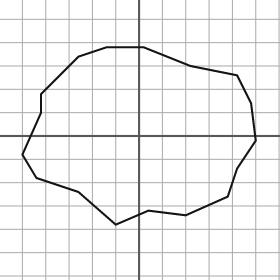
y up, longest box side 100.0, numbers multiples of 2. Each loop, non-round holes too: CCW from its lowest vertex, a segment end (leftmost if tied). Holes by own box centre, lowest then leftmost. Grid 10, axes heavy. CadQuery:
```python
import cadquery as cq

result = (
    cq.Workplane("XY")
    .moveTo(-10.0, -38.0)
    .lineTo(4.0, -32.0)
    .lineTo(20.0, -34.0)
    .lineTo(38.0, -26.0)
    .lineTo(42.0, -14.0)
    .lineTo(50.0, -2.0)
    .lineTo(48.0, 14.0)
    .lineTo(42.0, 26.0)
    .lineTo(22.0, 30.0)
    .lineTo(2.0, 38.0)
    .lineTo(-14.0, 38.0)
    .lineTo(-26.0, 34.0)
    .lineTo(-42.0, 18.0)
    .lineTo(-42.0, 10.0)
    .lineTo(-50.0, -8.0)
    .lineTo(-44.0, -18.0)
    .lineTo(-26.0, -24.0)
    .close()
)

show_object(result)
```